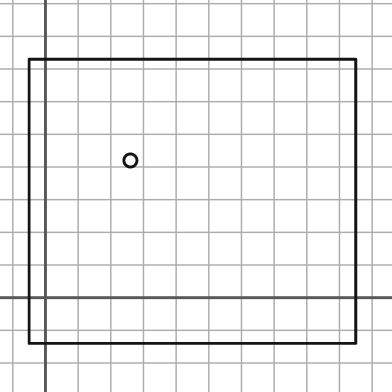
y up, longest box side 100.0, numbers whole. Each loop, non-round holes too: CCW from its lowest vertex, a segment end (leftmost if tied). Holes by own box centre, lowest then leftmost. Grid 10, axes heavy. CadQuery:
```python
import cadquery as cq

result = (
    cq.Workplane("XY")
    .moveTo(-5.0, -14.0)
    .lineTo(95.0, -14.0)
    .lineTo(95.0, 73.0)
    .lineTo(-5.0, 73.0)
    .close()
    .moveTo(26.0, 42.0)
    .circle(2.0)
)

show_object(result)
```